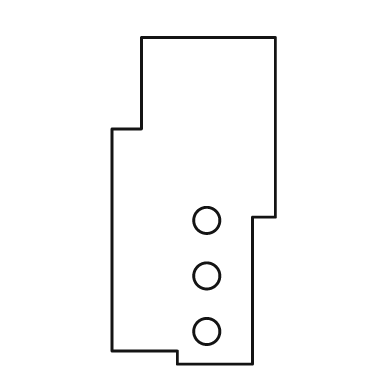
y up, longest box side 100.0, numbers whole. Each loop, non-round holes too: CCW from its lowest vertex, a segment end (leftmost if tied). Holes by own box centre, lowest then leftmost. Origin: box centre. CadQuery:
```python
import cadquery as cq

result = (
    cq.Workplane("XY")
    .moveTo(-5.0, -50.0)
    .lineTo(18.0, -50.0)
    .lineTo(18.0, -5.0)
    .lineTo(25.0, -5.0)
    .lineTo(25.0, 50.0)
    .lineTo(-16.0, 50.0)
    .lineTo(-16.0, 22.0)
    .lineTo(-25.0, 22.0)
    .lineTo(-25.0, -46.0)
    .lineTo(-5.0, -46.0)
    .close()
    .moveTo(4.0, -40.0)
    .circle(4.0)
    .moveTo(4.0, -23.0)
    .circle(4.0)
    .moveTo(4.0, -6.0)
    .circle(4.0)
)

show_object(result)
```